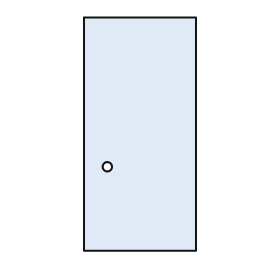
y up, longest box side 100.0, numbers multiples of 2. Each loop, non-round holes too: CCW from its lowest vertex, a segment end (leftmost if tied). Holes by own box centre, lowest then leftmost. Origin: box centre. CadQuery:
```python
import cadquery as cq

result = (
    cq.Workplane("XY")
    .moveTo(-24.0, -50.0)
    .lineTo(24.0, -50.0)
    .lineTo(24.0, 50.0)
    .lineTo(-24.0, 50.0)
    .close()
    .moveTo(-14.0, -14.0)
    .circle(2.0)
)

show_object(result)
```